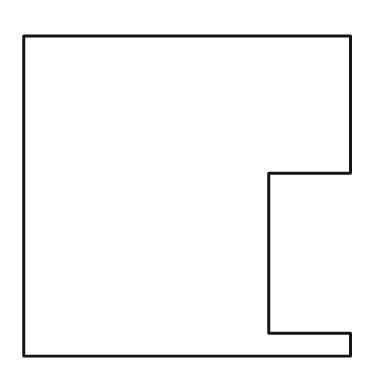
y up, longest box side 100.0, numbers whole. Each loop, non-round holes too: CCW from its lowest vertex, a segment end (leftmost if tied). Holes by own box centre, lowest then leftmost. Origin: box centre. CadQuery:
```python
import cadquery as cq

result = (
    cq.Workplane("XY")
    .moveTo(-50.0, -49.0)
    .lineTo(50.0, -49.0)
    .lineTo(50.0, -42.0)
    .lineTo(25.0, -42.0)
    .lineTo(25.0, 7.0)
    .lineTo(50.0, 7.0)
    .lineTo(50.0, 49.0)
    .lineTo(-50.0, 49.0)
    .close()
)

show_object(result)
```